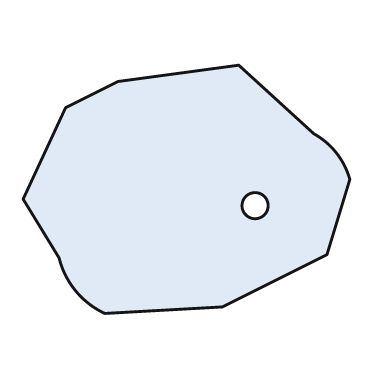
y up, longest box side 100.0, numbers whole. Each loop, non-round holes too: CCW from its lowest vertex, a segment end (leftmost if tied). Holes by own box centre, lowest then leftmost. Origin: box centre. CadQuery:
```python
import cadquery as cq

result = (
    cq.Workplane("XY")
    .moveTo(-25.0, -38.0)
    .lineTo(11.0, -36.0)
    .lineTo(43.0, -20.0)
    .lineTo(50.0, 3.0)
    .threePointArc((46.0, 11.0), (39.0, 17.0))
    .lineTo(16.0, 38.0)
    .lineTo(-21.0, 33.0)
    .lineTo(-37.0, 25.0)
    .lineTo(-50.0, -3.0)
    .lineTo(-39.0, -21.0)
    .threePointArc((-34.0, -31.0), (-25.0, -38.0))
    .close()
    .moveTo(21.0, -5.0)
    .circle(4.0)
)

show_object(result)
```